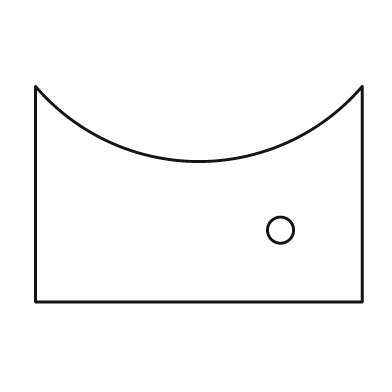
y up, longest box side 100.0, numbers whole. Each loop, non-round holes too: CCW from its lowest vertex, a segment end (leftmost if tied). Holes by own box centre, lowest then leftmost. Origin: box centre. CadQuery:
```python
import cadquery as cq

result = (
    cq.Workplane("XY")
    .moveTo(-50.0, -33.0)
    .lineTo(50.0, -33.0)
    .lineTo(50.0, 33.0)
    .threePointArc((0.0, 10.0), (-50.0, 33.0))
    .close()
    .moveTo(25.0, -11.0)
    .circle(4.0)
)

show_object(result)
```